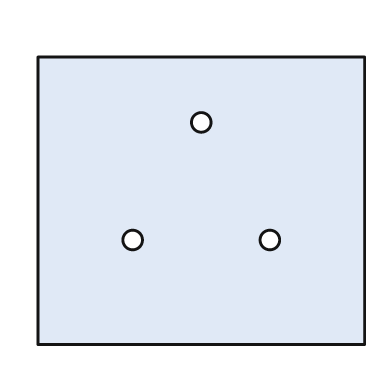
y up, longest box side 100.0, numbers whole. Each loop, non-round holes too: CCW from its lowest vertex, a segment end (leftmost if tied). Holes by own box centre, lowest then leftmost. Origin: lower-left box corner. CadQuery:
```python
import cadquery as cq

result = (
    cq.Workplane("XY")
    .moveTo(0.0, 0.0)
    .lineTo(100.0, 0.0)
    .lineTo(100.0, 88.0)
    .lineTo(0.0, 88.0)
    .close()
    .moveTo(29.0, 32.0)
    .circle(3.0)
    .moveTo(71.0, 32.0)
    .circle(3.0)
    .moveTo(50.0, 68.0)
    .circle(3.0)
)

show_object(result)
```